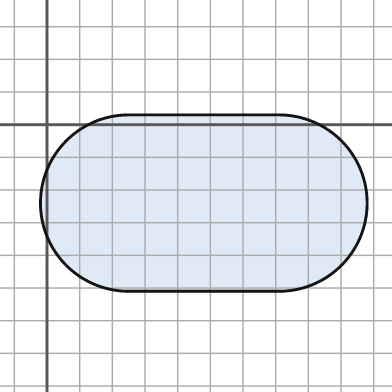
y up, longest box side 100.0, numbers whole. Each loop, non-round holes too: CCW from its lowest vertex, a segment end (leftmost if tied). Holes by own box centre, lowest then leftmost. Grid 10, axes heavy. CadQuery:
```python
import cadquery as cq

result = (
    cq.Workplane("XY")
    .moveTo(25.0, -51.0)
    .lineTo(71.0, -51.0)
    .threePointArc((98.0, -24.0), (71.0, 3.0))
    .lineTo(25.0, 3.0)
    .threePointArc((-2.0, -24.0), (25.0, -51.0))
    .close()
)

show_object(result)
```